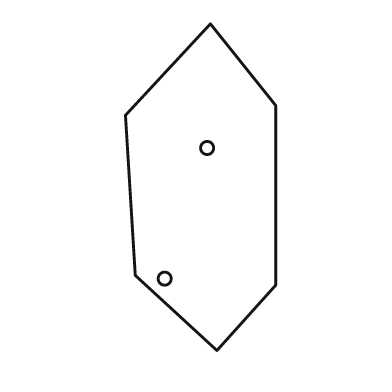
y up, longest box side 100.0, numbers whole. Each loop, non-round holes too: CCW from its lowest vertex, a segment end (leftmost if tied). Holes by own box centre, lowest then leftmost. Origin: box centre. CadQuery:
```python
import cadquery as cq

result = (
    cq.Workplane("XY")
    .moveTo(5.0, -50.0)
    .lineTo(23.0, -30.0)
    .lineTo(23.0, 25.0)
    .lineTo(3.0, 50.0)
    .lineTo(-23.0, 22.0)
    .lineTo(-20.0, -27.0)
    .close()
    .moveTo(-11.0, -28.0)
    .circle(2.0)
    .moveTo(2.0, 12.0)
    .circle(2.0)
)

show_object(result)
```